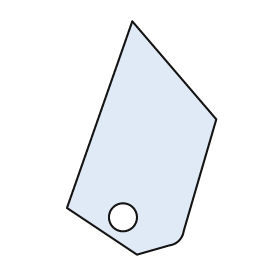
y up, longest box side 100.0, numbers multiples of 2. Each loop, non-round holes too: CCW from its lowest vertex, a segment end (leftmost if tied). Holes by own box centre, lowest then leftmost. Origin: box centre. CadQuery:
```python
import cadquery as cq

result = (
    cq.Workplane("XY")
    .moveTo(-2.0, -50.0)
    .lineTo(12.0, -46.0)
    .threePointArc((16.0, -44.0), (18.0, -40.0))
    .lineTo(32.0, 8.0)
    .lineTo(-4.0, 50.0)
    .lineTo(-32.0, -30.0)
    .close()
    .moveTo(-8.0, -34.0)
    .circle(6.0)
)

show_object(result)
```